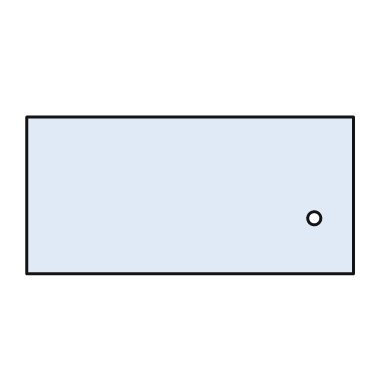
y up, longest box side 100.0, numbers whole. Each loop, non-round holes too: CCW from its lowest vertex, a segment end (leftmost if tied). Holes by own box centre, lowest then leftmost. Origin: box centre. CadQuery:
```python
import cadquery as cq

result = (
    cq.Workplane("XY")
    .moveTo(-50.0, -24.0)
    .lineTo(50.0, -24.0)
    .lineTo(50.0, 24.0)
    .lineTo(-50.0, 24.0)
    .close()
    .moveTo(38.0, -7.0)
    .circle(2.0)
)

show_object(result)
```